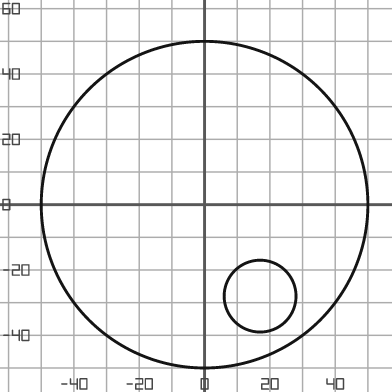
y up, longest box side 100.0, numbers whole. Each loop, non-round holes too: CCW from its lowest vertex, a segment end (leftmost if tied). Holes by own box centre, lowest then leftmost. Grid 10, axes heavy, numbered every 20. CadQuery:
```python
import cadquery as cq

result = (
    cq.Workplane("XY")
    .moveTo(0.0, 0.0)
    .circle(50.0)
    .moveTo(17.0, -28.0)
    .circle(11.0)
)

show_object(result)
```